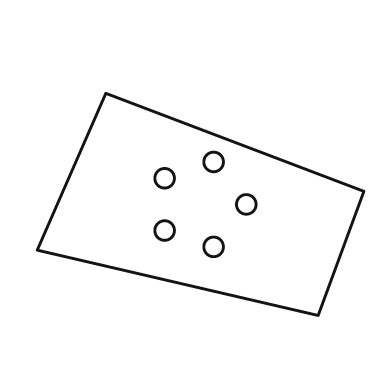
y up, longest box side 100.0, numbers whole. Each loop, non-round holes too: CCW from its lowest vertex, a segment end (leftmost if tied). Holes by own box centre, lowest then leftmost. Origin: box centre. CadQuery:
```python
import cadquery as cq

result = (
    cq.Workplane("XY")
    .moveTo(36.0, -34.0)
    .lineTo(50.0, 4.0)
    .lineTo(-29.0, 34.0)
    .lineTo(-50.0, -14.0)
    .close()
    .moveTo(4.0, -13.0)
    .circle(3.0)
    .moveTo(-11.0, -8.0)
    .circle(3.0)
    .moveTo(14.0, 0.0)
    .circle(3.0)
    .moveTo(-11.0, 8.0)
    .circle(3.0)
    .moveTo(4.0, 13.0)
    .circle(3.0)
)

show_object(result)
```